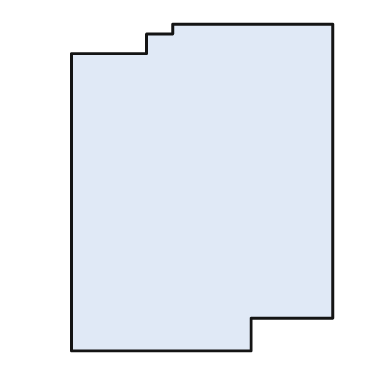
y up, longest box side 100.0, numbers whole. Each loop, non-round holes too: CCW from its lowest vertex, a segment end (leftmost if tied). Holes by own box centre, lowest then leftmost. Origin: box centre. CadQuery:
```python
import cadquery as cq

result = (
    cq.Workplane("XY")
    .moveTo(-40.0, -50.0)
    .lineTo(15.0, -50.0)
    .lineTo(15.0, -40.0)
    .lineTo(40.0, -40.0)
    .lineTo(40.0, 50.0)
    .lineTo(-9.0, 50.0)
    .lineTo(-9.0, 47.0)
    .lineTo(-17.0, 47.0)
    .lineTo(-17.0, 41.0)
    .lineTo(-40.0, 41.0)
    .close()
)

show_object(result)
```